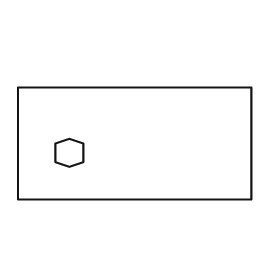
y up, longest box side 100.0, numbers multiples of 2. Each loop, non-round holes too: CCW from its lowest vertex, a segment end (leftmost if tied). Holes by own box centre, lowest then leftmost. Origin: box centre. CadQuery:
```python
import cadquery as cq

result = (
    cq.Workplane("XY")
    .moveTo(-50.0, -24.0)
    .lineTo(50.0, -24.0)
    .lineTo(50.0, 24.0)
    .lineTo(-50.0, 24.0)
    .close()
    .moveTo(-28.0, -10.0)
    .lineTo(-22.0, -8.0)
    .lineTo(-22.0, 0.0)
    .lineTo(-28.0, 2.0)
    .lineTo(-34.0, 0.0)
    .lineTo(-34.0, -8.0)
    .close()
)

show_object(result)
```